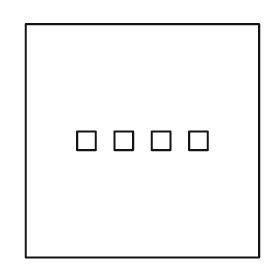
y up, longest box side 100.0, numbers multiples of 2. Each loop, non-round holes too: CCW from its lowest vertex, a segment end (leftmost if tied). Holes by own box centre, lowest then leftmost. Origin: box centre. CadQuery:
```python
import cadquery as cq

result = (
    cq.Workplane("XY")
    .moveTo(-50.0, -50.0)
    .lineTo(50.0, -50.0)
    .lineTo(50.0, 50.0)
    .lineTo(-50.0, 50.0)
    .close()
    .moveTo(-28.0, -4.0)
    .lineTo(-20.0, -4.0)
    .lineTo(-20.0, 4.0)
    .lineTo(-28.0, 4.0)
    .close()
    .moveTo(-12.0, -4.0)
    .lineTo(-4.0, -4.0)
    .lineTo(-4.0, 4.0)
    .lineTo(-12.0, 4.0)
    .close()
    .moveTo(4.0, -4.0)
    .lineTo(12.0, -4.0)
    .lineTo(12.0, 4.0)
    .lineTo(4.0, 4.0)
    .close()
    .moveTo(20.0, -4.0)
    .lineTo(28.0, -4.0)
    .lineTo(28.0, 4.0)
    .lineTo(20.0, 4.0)
    .close()
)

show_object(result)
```